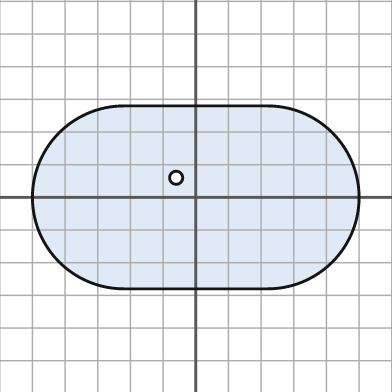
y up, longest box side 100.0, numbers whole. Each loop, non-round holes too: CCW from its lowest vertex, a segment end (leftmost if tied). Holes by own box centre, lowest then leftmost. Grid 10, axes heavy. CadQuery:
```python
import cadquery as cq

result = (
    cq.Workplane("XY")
    .moveTo(-22.0, -28.0)
    .lineTo(22.0, -28.0)
    .threePointArc((50.0, 0.0), (22.0, 28.0))
    .lineTo(-22.0, 28.0)
    .threePointArc((-50.0, 0.0), (-22.0, -28.0))
    .close()
    .moveTo(-6.0, 6.0)
    .circle(2.0)
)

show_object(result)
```